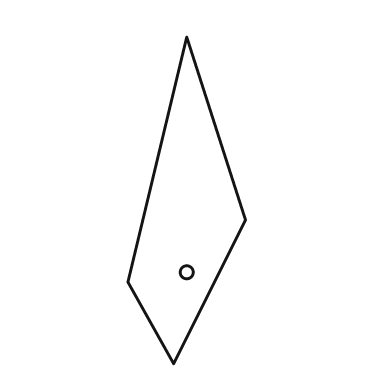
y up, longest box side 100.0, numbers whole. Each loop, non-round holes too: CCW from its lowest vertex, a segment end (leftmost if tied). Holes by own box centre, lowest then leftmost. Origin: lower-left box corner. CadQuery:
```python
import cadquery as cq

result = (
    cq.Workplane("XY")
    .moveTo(14.0, 0.0)
    .lineTo(36.0, 44.0)
    .lineTo(18.0, 100.0)
    .lineTo(0.0, 25.0)
    .close()
    .moveTo(18.0, 28.0)
    .circle(2.0)
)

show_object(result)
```